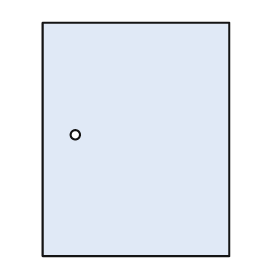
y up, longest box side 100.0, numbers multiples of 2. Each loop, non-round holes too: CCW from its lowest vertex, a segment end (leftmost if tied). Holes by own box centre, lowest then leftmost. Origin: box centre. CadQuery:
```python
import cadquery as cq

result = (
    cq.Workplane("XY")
    .moveTo(-40.0, -50.0)
    .lineTo(40.0, -50.0)
    .lineTo(40.0, 50.0)
    .lineTo(-40.0, 50.0)
    .close()
    .moveTo(-26.0, 2.0)
    .circle(2.0)
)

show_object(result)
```